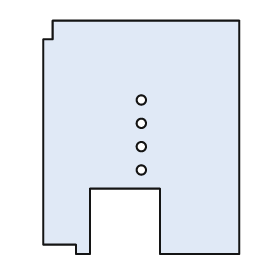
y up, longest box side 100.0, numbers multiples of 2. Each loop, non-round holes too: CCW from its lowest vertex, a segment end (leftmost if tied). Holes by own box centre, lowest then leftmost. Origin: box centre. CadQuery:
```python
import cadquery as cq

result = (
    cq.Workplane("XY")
    .moveTo(-28.0, -50.0)
    .lineTo(-22.0, -50.0)
    .lineTo(-22.0, -22.0)
    .lineTo(8.0, -22.0)
    .lineTo(8.0, -50.0)
    .lineTo(42.0, -50.0)
    .lineTo(42.0, 50.0)
    .lineTo(-38.0, 50.0)
    .lineTo(-38.0, 42.0)
    .lineTo(-42.0, 42.0)
    .lineTo(-42.0, -46.0)
    .lineTo(-28.0, -46.0)
    .close()
    .moveTo(0.0, -14.0)
    .circle(2.0)
    .moveTo(0.0, -4.0)
    .circle(2.0)
    .moveTo(0.0, 6.0)
    .circle(2.0)
    .moveTo(0.0, 16.0)
    .circle(2.0)
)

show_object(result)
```